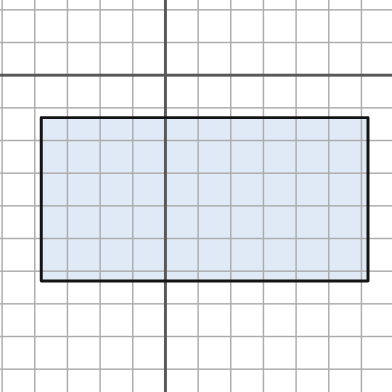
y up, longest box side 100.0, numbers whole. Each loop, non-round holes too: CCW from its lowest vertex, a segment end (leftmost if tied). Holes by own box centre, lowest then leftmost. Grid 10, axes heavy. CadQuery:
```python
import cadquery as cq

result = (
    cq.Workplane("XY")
    .moveTo(-38.0, -63.0)
    .lineTo(62.0, -63.0)
    .lineTo(62.0, -13.0)
    .lineTo(-38.0, -13.0)
    .close()
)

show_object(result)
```